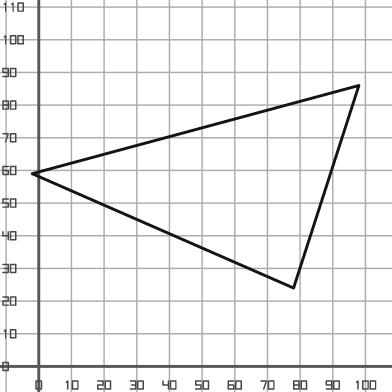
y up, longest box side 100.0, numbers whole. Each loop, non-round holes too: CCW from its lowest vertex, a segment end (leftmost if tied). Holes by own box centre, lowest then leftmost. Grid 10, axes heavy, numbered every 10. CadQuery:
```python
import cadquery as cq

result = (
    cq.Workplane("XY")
    .moveTo(78.0, 24.0)
    .lineTo(98.0, 86.0)
    .lineTo(-2.0, 59.0)
    .close()
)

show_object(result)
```